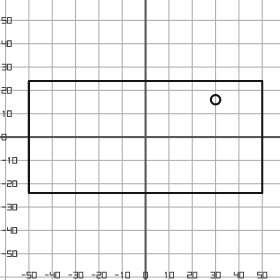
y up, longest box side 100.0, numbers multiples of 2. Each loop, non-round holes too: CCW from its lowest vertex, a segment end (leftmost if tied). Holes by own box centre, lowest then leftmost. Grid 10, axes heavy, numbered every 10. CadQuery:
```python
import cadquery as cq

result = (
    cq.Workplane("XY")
    .moveTo(-50.0, -24.0)
    .lineTo(50.0, -24.0)
    .lineTo(50.0, 24.0)
    .lineTo(-50.0, 24.0)
    .close()
    .moveTo(30.0, 16.0)
    .circle(2.0)
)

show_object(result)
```